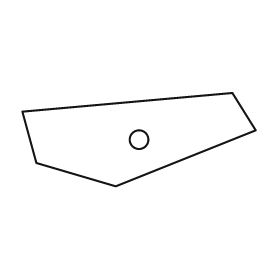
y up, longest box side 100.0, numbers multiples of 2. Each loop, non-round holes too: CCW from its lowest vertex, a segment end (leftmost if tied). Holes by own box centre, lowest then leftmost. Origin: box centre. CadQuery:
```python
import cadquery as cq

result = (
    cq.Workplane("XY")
    .moveTo(-10.0, -20.0)
    .lineTo(50.0, 4.0)
    .lineTo(40.0, 20.0)
    .lineTo(-50.0, 12.0)
    .lineTo(-44.0, -10.0)
    .close()
    .moveTo(0.0, 0.0)
    .circle(4.0)
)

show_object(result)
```